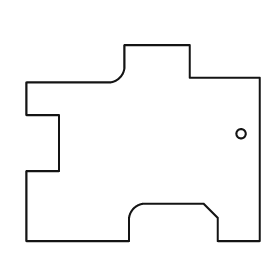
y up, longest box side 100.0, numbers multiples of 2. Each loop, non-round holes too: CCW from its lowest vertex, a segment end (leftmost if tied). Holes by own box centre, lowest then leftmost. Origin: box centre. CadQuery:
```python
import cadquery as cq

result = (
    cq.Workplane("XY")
    .moveTo(-50.0, -42.0)
    .lineTo(-6.0, -42.0)
    .lineTo(-6.0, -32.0)
    .threePointArc((-4.0, -28.0), (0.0, -26.0))
    .lineTo(26.0, -26.0)
    .lineTo(32.0, -32.0)
    .lineTo(32.0, -42.0)
    .lineTo(50.0, -42.0)
    .lineTo(50.0, 28.0)
    .lineTo(20.0, 28.0)
    .lineTo(20.0, 42.0)
    .lineTo(-8.0, 42.0)
    .lineTo(-8.0, 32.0)
    .threePointArc((-10.0, 28.0), (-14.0, 26.0))
    .lineTo(-50.0, 26.0)
    .lineTo(-50.0, 12.0)
    .lineTo(-36.0, 12.0)
    .lineTo(-36.0, -12.0)
    .lineTo(-50.0, -12.0)
    .close()
    .moveTo(42.0, 4.0)
    .circle(2.0)
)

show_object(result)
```